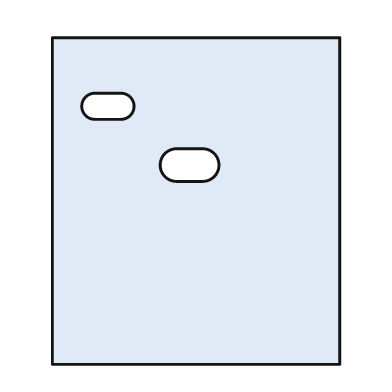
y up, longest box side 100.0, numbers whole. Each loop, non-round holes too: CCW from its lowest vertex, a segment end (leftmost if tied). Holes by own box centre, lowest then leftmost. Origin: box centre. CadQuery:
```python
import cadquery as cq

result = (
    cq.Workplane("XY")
    .moveTo(-44.0, -50.0)
    .lineTo(44.0, -50.0)
    .lineTo(44.0, 50.0)
    .lineTo(-44.0, 50.0)
    .close()
    .moveTo(-6.0, 6.0)
    .lineTo(2.0, 6.0)
    .threePointArc((7.0, 11.0), (2.0, 16.0))
    .lineTo(-6.0, 16.0)
    .threePointArc((-11.0, 11.0), (-6.0, 6.0))
    .close()
    .moveTo(-31.0, 25.0)
    .lineTo(-23.0, 25.0)
    .threePointArc((-19.0, 29.0), (-23.0, 33.0))
    .lineTo(-31.0, 33.0)
    .threePointArc((-35.0, 29.0), (-31.0, 25.0))
    .close()
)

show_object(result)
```